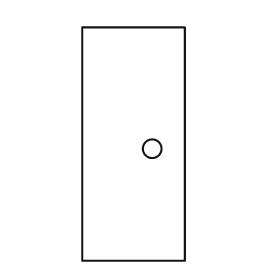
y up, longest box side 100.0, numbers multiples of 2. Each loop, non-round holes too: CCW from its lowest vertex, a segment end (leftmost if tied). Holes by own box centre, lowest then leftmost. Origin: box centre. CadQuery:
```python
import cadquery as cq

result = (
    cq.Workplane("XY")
    .moveTo(-22.0, -50.0)
    .lineTo(22.0, -50.0)
    .lineTo(22.0, 50.0)
    .lineTo(-22.0, 50.0)
    .close()
    .moveTo(8.0, -2.0)
    .circle(4.0)
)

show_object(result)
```